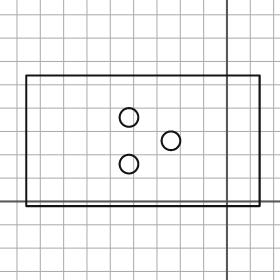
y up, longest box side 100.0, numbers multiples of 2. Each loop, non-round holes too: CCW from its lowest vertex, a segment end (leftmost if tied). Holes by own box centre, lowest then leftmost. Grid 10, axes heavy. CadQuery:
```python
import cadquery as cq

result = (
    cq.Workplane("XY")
    .moveTo(-86.0, -2.0)
    .lineTo(14.0, -2.0)
    .lineTo(14.0, 54.0)
    .lineTo(-86.0, 54.0)
    .close()
    .moveTo(-42.0, 16.0)
    .circle(4.0)
    .moveTo(-24.0, 26.0)
    .circle(4.0)
    .moveTo(-42.0, 36.0)
    .circle(4.0)
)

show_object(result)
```